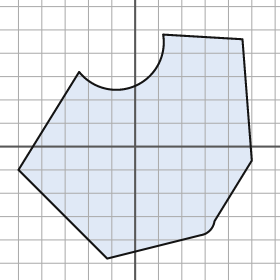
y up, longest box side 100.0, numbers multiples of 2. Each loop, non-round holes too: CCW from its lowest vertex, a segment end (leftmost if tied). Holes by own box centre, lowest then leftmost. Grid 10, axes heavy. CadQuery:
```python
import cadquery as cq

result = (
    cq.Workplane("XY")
    .moveTo(-12.0, -48.0)
    .lineTo(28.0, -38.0)
    .threePointArc((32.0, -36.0), (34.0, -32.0))
    .lineTo(50.0, -6.0)
    .lineTo(46.0, 46.0)
    .lineTo(12.0, 48.0)
    .threePointArc((0.0, 26.0), (-24.0, 32.0))
    .lineTo(-50.0, -10.0)
    .close()
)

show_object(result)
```